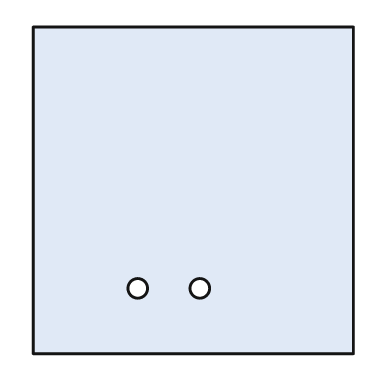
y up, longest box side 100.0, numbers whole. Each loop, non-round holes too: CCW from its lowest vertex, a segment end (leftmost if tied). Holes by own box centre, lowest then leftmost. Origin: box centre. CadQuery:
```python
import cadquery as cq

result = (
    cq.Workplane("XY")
    .moveTo(-49.0, -50.0)
    .lineTo(49.0, -50.0)
    .lineTo(49.0, 50.0)
    .lineTo(-49.0, 50.0)
    .close()
    .moveTo(-17.0, -30.0)
    .circle(3.0)
    .moveTo(2.0, -30.0)
    .circle(3.0)
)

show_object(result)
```